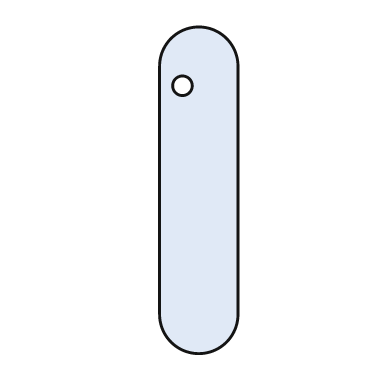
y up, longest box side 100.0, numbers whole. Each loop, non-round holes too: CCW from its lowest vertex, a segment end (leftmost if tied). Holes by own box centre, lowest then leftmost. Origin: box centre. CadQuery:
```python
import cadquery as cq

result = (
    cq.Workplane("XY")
    .moveTo(-12.0, -38.0)
    .threePointArc((0.0, -50.0), (12.0, -38.0))
    .lineTo(12.0, 38.0)
    .threePointArc((0.0, 50.0), (-12.0, 38.0))
    .close()
    .moveTo(-5.0, 32.0)
    .circle(3.0)
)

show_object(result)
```